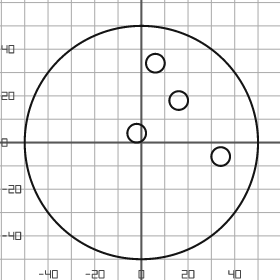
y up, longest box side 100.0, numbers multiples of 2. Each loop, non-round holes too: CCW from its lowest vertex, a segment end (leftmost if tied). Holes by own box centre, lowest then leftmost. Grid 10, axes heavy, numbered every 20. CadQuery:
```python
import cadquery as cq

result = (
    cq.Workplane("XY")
    .moveTo(0.0, 0.0)
    .circle(50.0)
    .moveTo(34.0, -6.0)
    .circle(4.0)
    .moveTo(-2.0, 4.0)
    .circle(4.0)
    .moveTo(16.0, 18.0)
    .circle(4.0)
    .moveTo(6.0, 34.0)
    .circle(4.0)
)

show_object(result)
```